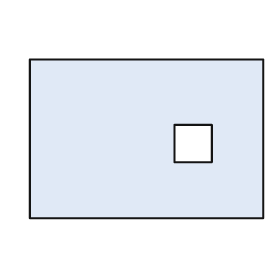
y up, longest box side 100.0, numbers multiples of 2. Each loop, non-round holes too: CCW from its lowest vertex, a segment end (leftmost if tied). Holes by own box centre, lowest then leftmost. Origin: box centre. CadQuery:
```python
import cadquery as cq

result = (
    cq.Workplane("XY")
    .moveTo(-50.0, -34.0)
    .lineTo(50.0, -34.0)
    .lineTo(50.0, 34.0)
    .lineTo(-50.0, 34.0)
    .close()
    .moveTo(12.0, -10.0)
    .lineTo(28.0, -10.0)
    .lineTo(28.0, 6.0)
    .lineTo(12.0, 6.0)
    .close()
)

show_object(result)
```